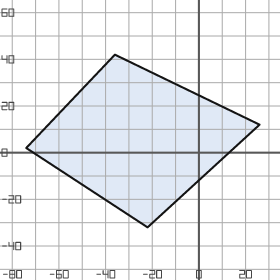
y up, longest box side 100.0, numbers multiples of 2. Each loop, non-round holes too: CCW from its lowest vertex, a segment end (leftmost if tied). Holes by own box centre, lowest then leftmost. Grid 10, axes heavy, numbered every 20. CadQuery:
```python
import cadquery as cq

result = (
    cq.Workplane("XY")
    .moveTo(-22.0, -32.0)
    .lineTo(26.0, 12.0)
    .lineTo(-36.0, 42.0)
    .lineTo(-74.0, 2.0)
    .close()
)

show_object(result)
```